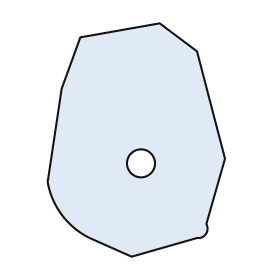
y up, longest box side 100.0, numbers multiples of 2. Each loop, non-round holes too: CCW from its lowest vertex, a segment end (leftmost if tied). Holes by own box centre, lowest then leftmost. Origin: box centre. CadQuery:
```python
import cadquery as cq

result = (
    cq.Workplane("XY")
    .moveTo(-2.0, -50.0)
    .lineTo(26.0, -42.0)
    .threePointArc((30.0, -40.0), (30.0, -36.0))
    .lineTo(38.0, -8.0)
    .lineTo(26.0, 38.0)
    .lineTo(10.0, 50.0)
    .lineTo(-24.0, 44.0)
    .lineTo(-32.0, 22.0)
    .lineTo(-38.0, -18.0)
    .threePointArc((-32.0, -32.0), (-20.0, -42.0))
    .close()
    .moveTo(2.0, -10.0)
    .circle(6.0)
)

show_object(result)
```